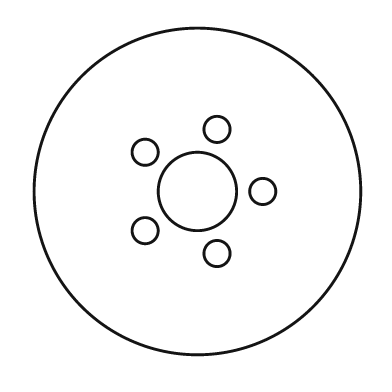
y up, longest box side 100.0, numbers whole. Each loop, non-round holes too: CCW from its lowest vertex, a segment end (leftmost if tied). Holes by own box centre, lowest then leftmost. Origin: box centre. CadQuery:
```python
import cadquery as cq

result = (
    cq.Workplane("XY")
    .moveTo(0.0, 0.0)
    .circle(50.0)
    .moveTo(6.0, -19.0)
    .circle(4.0)
    .moveTo(-16.0, -12.0)
    .circle(4.0)
    .moveTo(0.0, 0.0)
    .circle(12.0)
    .moveTo(20.0, 0.0)
    .circle(4.0)
    .moveTo(-16.0, 12.0)
    .circle(4.0)
    .moveTo(6.0, 19.0)
    .circle(4.0)
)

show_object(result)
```